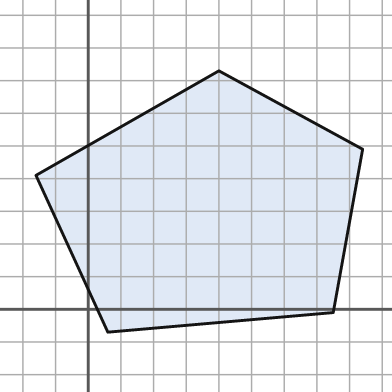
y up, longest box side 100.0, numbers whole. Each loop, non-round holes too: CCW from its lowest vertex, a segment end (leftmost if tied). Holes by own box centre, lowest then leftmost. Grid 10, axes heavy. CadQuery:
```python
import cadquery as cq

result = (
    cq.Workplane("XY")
    .moveTo(6.0, -7.0)
    .lineTo(75.0, -1.0)
    .lineTo(84.0, 49.0)
    .lineTo(40.0, 73.0)
    .lineTo(-16.0, 41.0)
    .close()
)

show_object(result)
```